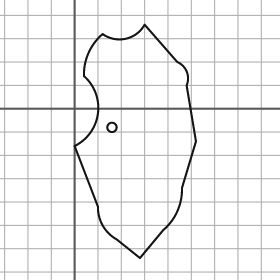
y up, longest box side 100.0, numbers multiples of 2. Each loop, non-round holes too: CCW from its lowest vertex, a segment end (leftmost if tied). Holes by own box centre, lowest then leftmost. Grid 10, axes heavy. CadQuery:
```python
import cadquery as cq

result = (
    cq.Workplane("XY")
    .moveTo(28.0, -64.0)
    .lineTo(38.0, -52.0)
    .threePointArc((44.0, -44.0), (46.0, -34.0))
    .lineTo(52.0, -14.0)
    .lineTo(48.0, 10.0)
    .threePointArc((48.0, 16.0), (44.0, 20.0))
    .lineTo(30.0, 36.0)
    .threePointArc((22.0, 30.0), (12.0, 32.0))
    .threePointArc((6.0, 24.0), (4.0, 14.0))
    .threePointArc((10.0, -2.0), (0.0, -16.0))
    .lineTo(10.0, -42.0)
    .threePointArc((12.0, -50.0), (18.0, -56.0))
    .close()
    .moveTo(16.0, -8.0)
    .circle(2.0)
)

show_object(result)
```